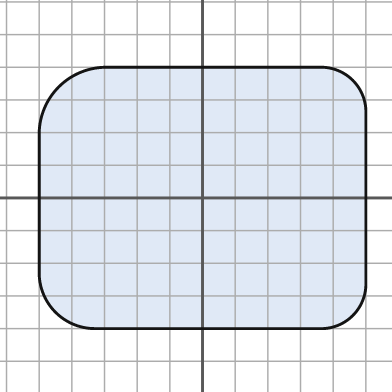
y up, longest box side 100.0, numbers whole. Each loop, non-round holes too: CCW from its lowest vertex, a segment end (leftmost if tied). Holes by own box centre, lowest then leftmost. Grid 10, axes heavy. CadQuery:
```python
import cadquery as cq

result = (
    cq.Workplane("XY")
    .moveTo(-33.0, -40.0)
    .lineTo(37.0, -40.0)
    .threePointArc((46.0, -36.0), (50.0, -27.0))
    .lineTo(50.0, 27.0)
    .threePointArc((46.0, 36.0), (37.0, 40.0))
    .lineTo(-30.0, 40.0)
    .threePointArc((-44.0, 34.0), (-50.0, 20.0))
    .lineTo(-50.0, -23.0)
    .threePointArc((-45.0, -35.0), (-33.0, -40.0))
    .close()
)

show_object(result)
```